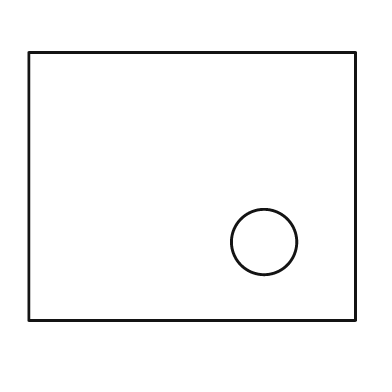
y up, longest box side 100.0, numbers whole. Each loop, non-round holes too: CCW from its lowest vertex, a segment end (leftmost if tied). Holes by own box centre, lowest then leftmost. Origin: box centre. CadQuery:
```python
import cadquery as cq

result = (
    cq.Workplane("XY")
    .moveTo(-50.0, -41.0)
    .lineTo(50.0, -41.0)
    .lineTo(50.0, 41.0)
    .lineTo(-50.0, 41.0)
    .close()
    .moveTo(22.0, -17.0)
    .circle(10.0)
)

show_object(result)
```